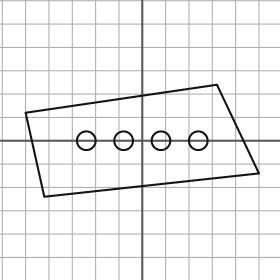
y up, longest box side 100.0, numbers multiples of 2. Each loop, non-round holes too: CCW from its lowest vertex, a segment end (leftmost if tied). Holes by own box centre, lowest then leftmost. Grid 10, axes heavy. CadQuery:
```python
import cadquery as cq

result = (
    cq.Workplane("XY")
    .moveTo(-42.0, -24.0)
    .lineTo(50.0, -14.0)
    .lineTo(32.0, 24.0)
    .lineTo(-50.0, 12.0)
    .close()
    .moveTo(-24.0, 0.0)
    .circle(4.0)
    .moveTo(-8.0, 0.0)
    .circle(4.0)
    .moveTo(8.0, 0.0)
    .circle(4.0)
    .moveTo(24.0, 0.0)
    .circle(4.0)
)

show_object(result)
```